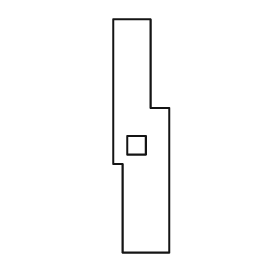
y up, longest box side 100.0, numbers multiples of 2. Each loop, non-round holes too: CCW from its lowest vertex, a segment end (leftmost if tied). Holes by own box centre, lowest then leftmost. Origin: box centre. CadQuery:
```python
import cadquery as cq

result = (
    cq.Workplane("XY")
    .moveTo(-8.0, -50.0)
    .lineTo(12.0, -50.0)
    .lineTo(12.0, 12.0)
    .lineTo(4.0, 12.0)
    .lineTo(4.0, 50.0)
    .lineTo(-12.0, 50.0)
    .lineTo(-12.0, -12.0)
    .lineTo(-8.0, -12.0)
    .close()
    .moveTo(-6.0, -8.0)
    .lineTo(2.0, -8.0)
    .lineTo(2.0, 0.0)
    .lineTo(-6.0, 0.0)
    .close()
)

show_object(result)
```